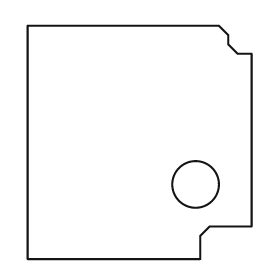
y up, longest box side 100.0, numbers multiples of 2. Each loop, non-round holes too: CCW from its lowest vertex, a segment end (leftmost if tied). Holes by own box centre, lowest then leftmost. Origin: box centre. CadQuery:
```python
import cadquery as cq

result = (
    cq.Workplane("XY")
    .moveTo(-48.0, -50.0)
    .lineTo(26.0, -50.0)
    .lineTo(26.0, -40.0)
    .lineTo(30.0, -36.0)
    .lineTo(48.0, -36.0)
    .lineTo(48.0, 38.0)
    .lineTo(42.0, 38.0)
    .lineTo(38.0, 42.0)
    .lineTo(38.0, 46.0)
    .lineTo(34.0, 50.0)
    .lineTo(-48.0, 50.0)
    .close()
    .moveTo(24.0, -18.0)
    .circle(10.0)
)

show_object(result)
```